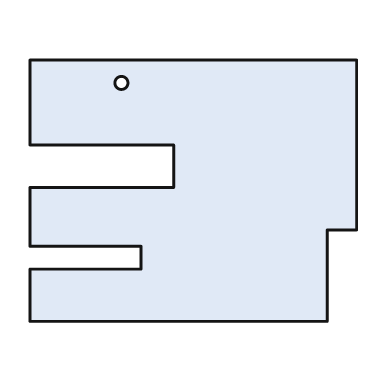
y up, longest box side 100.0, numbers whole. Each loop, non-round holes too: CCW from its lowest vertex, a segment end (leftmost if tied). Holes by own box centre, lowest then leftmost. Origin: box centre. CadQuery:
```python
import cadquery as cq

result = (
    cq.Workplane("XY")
    .moveTo(-50.0, -40.0)
    .lineTo(41.0, -40.0)
    .lineTo(41.0, -12.0)
    .lineTo(50.0, -12.0)
    .lineTo(50.0, 40.0)
    .lineTo(-50.0, 40.0)
    .lineTo(-50.0, 14.0)
    .lineTo(-6.0, 14.0)
    .lineTo(-6.0, 1.0)
    .lineTo(-50.0, 1.0)
    .lineTo(-50.0, -17.0)
    .lineTo(-16.0, -17.0)
    .lineTo(-16.0, -24.0)
    .lineTo(-50.0, -24.0)
    .close()
    .moveTo(-22.0, 33.0)
    .circle(2.0)
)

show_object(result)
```